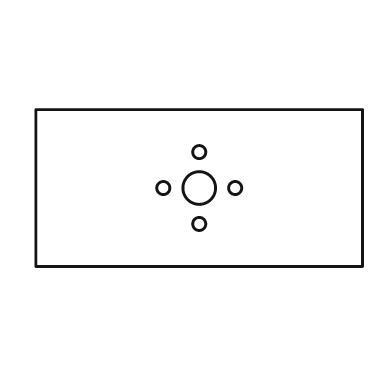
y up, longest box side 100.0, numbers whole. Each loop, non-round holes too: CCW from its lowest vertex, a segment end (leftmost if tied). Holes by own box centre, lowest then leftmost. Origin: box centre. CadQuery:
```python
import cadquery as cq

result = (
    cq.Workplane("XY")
    .moveTo(-50.0, -24.0)
    .lineTo(50.0, -24.0)
    .lineTo(50.0, 24.0)
    .lineTo(-50.0, 24.0)
    .close()
    .moveTo(0.0, -11.0)
    .circle(2.0)
    .moveTo(-11.0, 0.0)
    .circle(2.0)
    .moveTo(0.0, 0.0)
    .circle(5.0)
    .moveTo(11.0, 0.0)
    .circle(2.0)
    .moveTo(0.0, 11.0)
    .circle(2.0)
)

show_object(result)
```